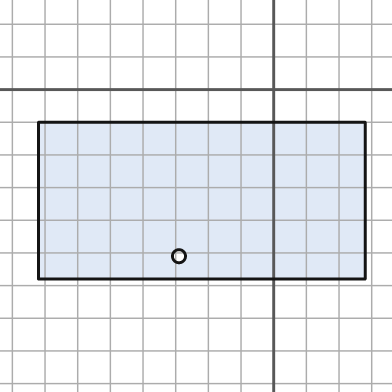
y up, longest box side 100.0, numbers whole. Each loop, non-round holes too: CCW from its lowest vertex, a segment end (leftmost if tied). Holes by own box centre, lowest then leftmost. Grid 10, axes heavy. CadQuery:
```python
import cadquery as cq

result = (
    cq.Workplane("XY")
    .moveTo(-72.0, -58.0)
    .lineTo(28.0, -58.0)
    .lineTo(28.0, -10.0)
    .lineTo(-72.0, -10.0)
    .close()
    .moveTo(-29.0, -51.0)
    .circle(2.0)
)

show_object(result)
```